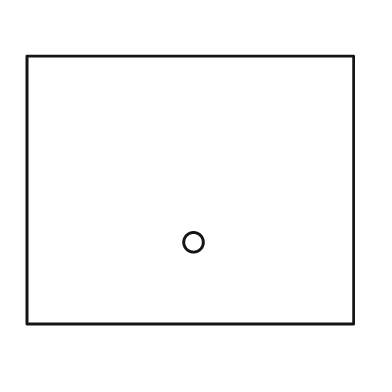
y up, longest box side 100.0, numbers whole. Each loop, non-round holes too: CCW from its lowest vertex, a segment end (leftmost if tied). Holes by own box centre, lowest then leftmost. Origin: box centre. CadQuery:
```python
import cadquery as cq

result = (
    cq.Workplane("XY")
    .moveTo(-50.0, -41.0)
    .lineTo(50.0, -41.0)
    .lineTo(50.0, 41.0)
    .lineTo(-50.0, 41.0)
    .close()
    .moveTo(1.0, -16.0)
    .circle(3.0)
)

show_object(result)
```